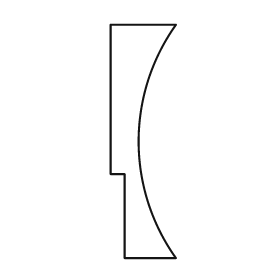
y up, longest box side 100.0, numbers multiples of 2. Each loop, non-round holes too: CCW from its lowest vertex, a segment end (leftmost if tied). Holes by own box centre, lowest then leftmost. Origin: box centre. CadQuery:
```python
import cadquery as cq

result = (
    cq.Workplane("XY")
    .moveTo(-8.0, -50.0)
    .lineTo(14.0, -50.0)
    .threePointArc((-2.0, 0.0), (14.0, 50.0))
    .lineTo(-14.0, 50.0)
    .lineTo(-14.0, -14.0)
    .lineTo(-8.0, -14.0)
    .close()
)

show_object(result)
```